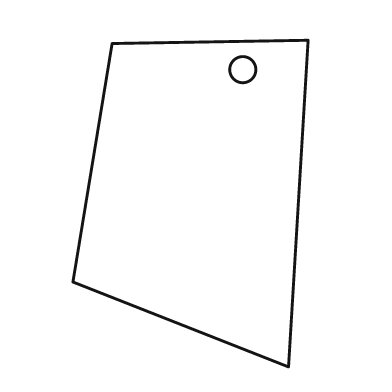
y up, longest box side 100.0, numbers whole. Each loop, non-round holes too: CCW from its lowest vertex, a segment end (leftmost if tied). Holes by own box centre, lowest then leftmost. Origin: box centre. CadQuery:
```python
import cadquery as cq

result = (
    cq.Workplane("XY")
    .moveTo(30.0, -50.0)
    .lineTo(36.0, 50.0)
    .lineTo(-24.0, 49.0)
    .lineTo(-36.0, -24.0)
    .close()
    .moveTo(16.0, 41.0)
    .circle(4.0)
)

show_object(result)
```